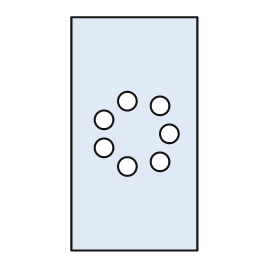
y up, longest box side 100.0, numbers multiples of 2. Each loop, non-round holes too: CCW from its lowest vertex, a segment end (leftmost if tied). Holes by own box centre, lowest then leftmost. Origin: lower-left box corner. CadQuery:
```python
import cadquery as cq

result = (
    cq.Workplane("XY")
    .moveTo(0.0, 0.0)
    .lineTo(54.0, 0.0)
    .lineTo(54.0, 100.0)
    .lineTo(0.0, 100.0)
    .close()
    .moveTo(24.0, 36.0)
    .circle(4.0)
    .moveTo(38.0, 38.0)
    .circle(4.0)
    .moveTo(14.0, 44.0)
    .circle(4.0)
    .moveTo(42.0, 50.0)
    .circle(4.0)
    .moveTo(14.0, 56.0)
    .circle(4.0)
    .moveTo(38.0, 62.0)
    .circle(4.0)
    .moveTo(24.0, 64.0)
    .circle(4.0)
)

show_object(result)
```